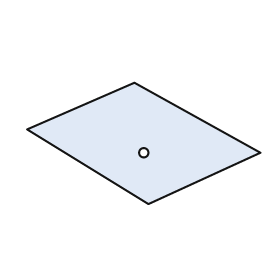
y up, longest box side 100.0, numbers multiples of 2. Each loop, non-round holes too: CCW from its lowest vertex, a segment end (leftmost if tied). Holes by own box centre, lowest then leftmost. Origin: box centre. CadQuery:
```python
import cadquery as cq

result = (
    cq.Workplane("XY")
    .moveTo(2.0, -26.0)
    .lineTo(50.0, -4.0)
    .lineTo(-4.0, 26.0)
    .lineTo(-50.0, 6.0)
    .close()
    .moveTo(0.0, -4.0)
    .circle(2.0)
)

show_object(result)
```